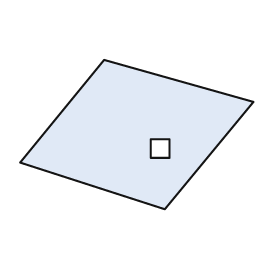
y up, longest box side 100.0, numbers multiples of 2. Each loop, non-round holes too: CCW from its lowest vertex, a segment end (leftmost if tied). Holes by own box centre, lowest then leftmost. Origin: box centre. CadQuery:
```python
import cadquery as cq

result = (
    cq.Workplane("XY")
    .moveTo(12.0, -32.0)
    .lineTo(50.0, 14.0)
    .lineTo(-14.0, 32.0)
    .lineTo(-50.0, -12.0)
    .close()
    .moveTo(6.0, -10.0)
    .lineTo(14.0, -10.0)
    .lineTo(14.0, -2.0)
    .lineTo(6.0, -2.0)
    .close()
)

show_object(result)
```